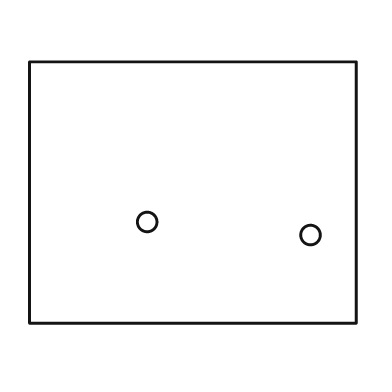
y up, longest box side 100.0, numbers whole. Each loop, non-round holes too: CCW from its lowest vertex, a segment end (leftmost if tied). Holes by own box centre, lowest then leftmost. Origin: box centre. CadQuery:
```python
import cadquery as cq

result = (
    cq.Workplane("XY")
    .moveTo(-50.0, -40.0)
    .lineTo(50.0, -40.0)
    .lineTo(50.0, 40.0)
    .lineTo(-50.0, 40.0)
    .close()
    .moveTo(36.0, -13.0)
    .circle(3.0)
    .moveTo(-14.0, -9.0)
    .circle(3.0)
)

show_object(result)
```